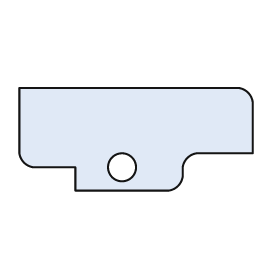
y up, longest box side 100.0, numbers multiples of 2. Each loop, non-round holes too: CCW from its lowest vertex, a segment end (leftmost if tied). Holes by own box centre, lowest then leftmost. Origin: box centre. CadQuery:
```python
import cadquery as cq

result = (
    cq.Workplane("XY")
    .moveTo(-26.0, -22.0)
    .lineTo(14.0, -22.0)
    .threePointArc((18.0, -20.0), (20.0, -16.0))
    .lineTo(20.0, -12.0)
    .threePointArc((22.0, -8.0), (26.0, -6.0))
    .lineTo(50.0, -6.0)
    .lineTo(50.0, 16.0)
    .threePointArc((48.0, 20.0), (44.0, 22.0))
    .lineTo(-50.0, 22.0)
    .lineTo(-50.0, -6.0)
    .threePointArc((-48.0, -10.0), (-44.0, -12.0))
    .lineTo(-26.0, -12.0)
    .close()
    .moveTo(-6.0, -12.0)
    .circle(6.0)
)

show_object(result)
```